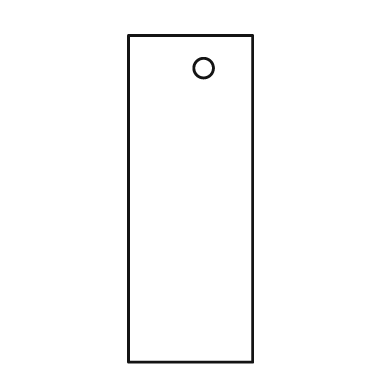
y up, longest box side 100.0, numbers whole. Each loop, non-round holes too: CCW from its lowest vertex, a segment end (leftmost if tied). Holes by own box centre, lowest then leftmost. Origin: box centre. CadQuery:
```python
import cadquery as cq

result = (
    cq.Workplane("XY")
    .moveTo(-19.0, -50.0)
    .lineTo(19.0, -50.0)
    .lineTo(19.0, 50.0)
    .lineTo(-19.0, 50.0)
    .close()
    .moveTo(4.0, 40.0)
    .circle(3.0)
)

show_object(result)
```